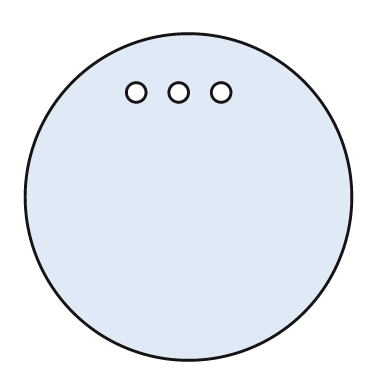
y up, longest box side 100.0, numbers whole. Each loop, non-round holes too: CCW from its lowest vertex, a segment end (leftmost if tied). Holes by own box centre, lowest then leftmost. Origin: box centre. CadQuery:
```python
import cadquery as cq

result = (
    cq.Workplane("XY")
    .moveTo(0.0, 0.0)
    .circle(50.0)
    .moveTo(-16.0, 32.0)
    .circle(3.0)
    .moveTo(-3.0, 32.0)
    .circle(3.0)
    .moveTo(10.0, 32.0)
    .circle(3.0)
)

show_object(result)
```